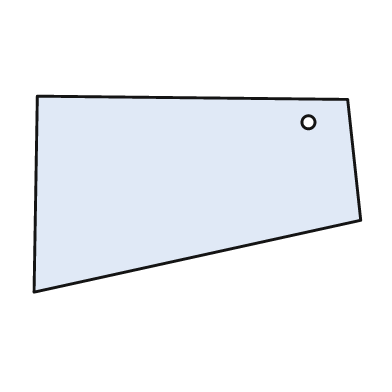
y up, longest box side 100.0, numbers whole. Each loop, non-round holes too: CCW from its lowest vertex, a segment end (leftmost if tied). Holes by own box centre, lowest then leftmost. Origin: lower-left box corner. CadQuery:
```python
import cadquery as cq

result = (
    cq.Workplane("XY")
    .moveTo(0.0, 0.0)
    .lineTo(100.0, 22.0)
    .lineTo(96.0, 59.0)
    .lineTo(1.0, 60.0)
    .close()
    .moveTo(84.0, 52.0)
    .circle(2.0)
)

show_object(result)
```